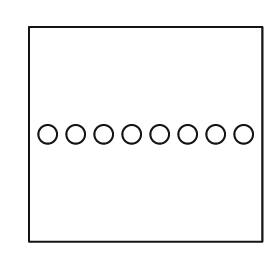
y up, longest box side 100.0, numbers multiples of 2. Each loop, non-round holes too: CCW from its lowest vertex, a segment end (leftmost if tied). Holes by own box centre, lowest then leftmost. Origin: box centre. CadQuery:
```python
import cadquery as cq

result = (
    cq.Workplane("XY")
    .moveTo(-50.0, -46.0)
    .lineTo(50.0, -46.0)
    .lineTo(50.0, 46.0)
    .lineTo(-50.0, 46.0)
    .close()
    .moveTo(-42.0, 0.0)
    .circle(4.0)
    .moveTo(-30.0, 0.0)
    .circle(4.0)
    .moveTo(-18.0, 0.0)
    .circle(4.0)
    .moveTo(-6.0, 0.0)
    .circle(4.0)
    .moveTo(6.0, 0.0)
    .circle(4.0)
    .moveTo(18.0, 0.0)
    .circle(4.0)
    .moveTo(30.0, 0.0)
    .circle(4.0)
    .moveTo(42.0, 0.0)
    .circle(4.0)
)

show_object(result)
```